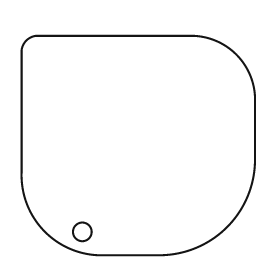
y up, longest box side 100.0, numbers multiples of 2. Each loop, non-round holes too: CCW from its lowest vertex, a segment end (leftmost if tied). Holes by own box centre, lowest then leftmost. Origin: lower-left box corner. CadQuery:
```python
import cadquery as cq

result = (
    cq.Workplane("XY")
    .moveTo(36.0, 0.0)
    .lineTo(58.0, 0.0)
    .threePointArc((88.0, 12.0), (100.0, 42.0))
    .lineTo(100.0, 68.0)
    .threePointArc((92.0, 86.0), (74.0, 94.0))
    .lineTo(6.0, 94.0)
    .threePointArc((2.0, 92.0), (0.0, 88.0))
    .lineTo(0.0, 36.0)
    .threePointArc((10.0, 10.0), (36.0, 0.0))
    .close()
    .moveTo(26.0, 10.0)
    .circle(4.0)
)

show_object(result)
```